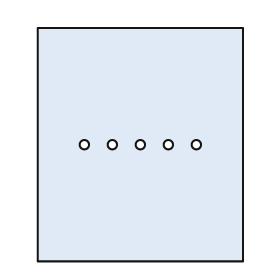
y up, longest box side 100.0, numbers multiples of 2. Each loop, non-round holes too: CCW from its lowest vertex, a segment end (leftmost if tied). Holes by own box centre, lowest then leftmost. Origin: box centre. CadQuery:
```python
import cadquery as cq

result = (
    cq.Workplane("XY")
    .moveTo(-44.0, -50.0)
    .lineTo(44.0, -50.0)
    .lineTo(44.0, 50.0)
    .lineTo(-44.0, 50.0)
    .close()
    .moveTo(-24.0, 0.0)
    .circle(2.0)
    .moveTo(-12.0, 0.0)
    .circle(2.0)
    .moveTo(0.0, 0.0)
    .circle(2.0)
    .moveTo(12.0, 0.0)
    .circle(2.0)
    .moveTo(24.0, 0.0)
    .circle(2.0)
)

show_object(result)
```